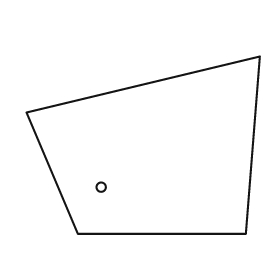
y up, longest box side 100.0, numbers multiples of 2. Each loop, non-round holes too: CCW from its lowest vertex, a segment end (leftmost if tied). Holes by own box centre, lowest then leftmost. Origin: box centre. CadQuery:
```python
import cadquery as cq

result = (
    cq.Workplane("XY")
    .moveTo(-28.0, -38.0)
    .lineTo(44.0, -38.0)
    .lineTo(50.0, 38.0)
    .lineTo(-50.0, 14.0)
    .close()
    .moveTo(-18.0, -18.0)
    .circle(2.0)
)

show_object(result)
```